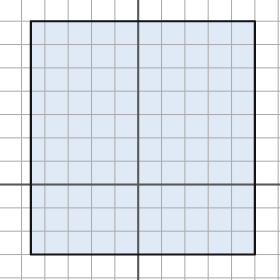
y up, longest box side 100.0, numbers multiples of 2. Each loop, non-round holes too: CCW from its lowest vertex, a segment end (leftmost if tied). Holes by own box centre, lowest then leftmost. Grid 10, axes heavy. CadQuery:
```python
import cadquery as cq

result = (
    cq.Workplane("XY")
    .moveTo(-46.0, -30.0)
    .lineTo(50.0, -30.0)
    .lineTo(50.0, 70.0)
    .lineTo(-46.0, 70.0)
    .close()
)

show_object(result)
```